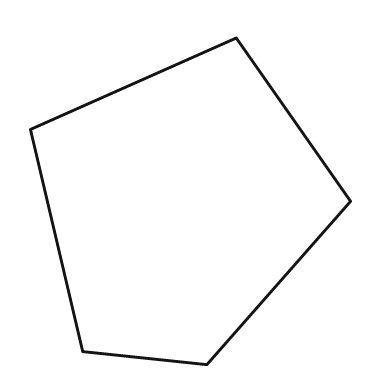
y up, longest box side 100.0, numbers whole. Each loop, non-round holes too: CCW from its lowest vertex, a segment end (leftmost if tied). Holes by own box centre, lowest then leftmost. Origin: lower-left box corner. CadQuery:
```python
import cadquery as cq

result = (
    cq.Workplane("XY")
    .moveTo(54.0, 0.0)
    .lineTo(98.0, 50.0)
    .lineTo(63.0, 100.0)
    .lineTo(0.0, 72.0)
    .lineTo(16.0, 4.0)
    .close()
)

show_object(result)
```